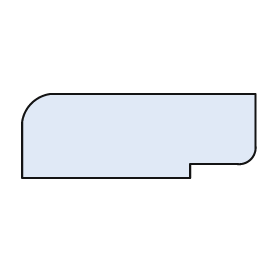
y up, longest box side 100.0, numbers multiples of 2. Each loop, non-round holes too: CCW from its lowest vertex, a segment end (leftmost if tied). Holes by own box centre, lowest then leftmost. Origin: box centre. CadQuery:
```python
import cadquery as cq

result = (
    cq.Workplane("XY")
    .moveTo(-50.0, -18.0)
    .lineTo(22.0, -18.0)
    .lineTo(22.0, -12.0)
    .lineTo(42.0, -12.0)
    .threePointArc((48.0, -10.0), (50.0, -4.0))
    .lineTo(50.0, 18.0)
    .lineTo(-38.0, 18.0)
    .threePointArc((-46.0, 14.0), (-50.0, 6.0))
    .close()
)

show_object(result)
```